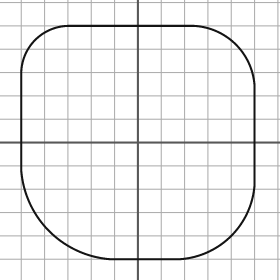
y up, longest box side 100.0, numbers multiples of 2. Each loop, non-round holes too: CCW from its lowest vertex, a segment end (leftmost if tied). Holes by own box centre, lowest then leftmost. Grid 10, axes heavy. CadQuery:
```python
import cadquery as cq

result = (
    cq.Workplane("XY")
    .moveTo(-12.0, -50.0)
    .lineTo(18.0, -50.0)
    .threePointArc((40.0, -40.0), (50.0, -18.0))
    .lineTo(50.0, 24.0)
    .threePointArc((42.0, 42.0), (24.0, 50.0))
    .lineTo(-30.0, 50.0)
    .threePointArc((-44.0, 44.0), (-50.0, 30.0))
    .lineTo(-50.0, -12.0)
    .threePointArc((-38.0, -38.0), (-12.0, -50.0))
    .close()
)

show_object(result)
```